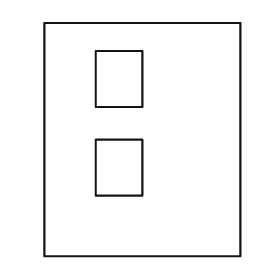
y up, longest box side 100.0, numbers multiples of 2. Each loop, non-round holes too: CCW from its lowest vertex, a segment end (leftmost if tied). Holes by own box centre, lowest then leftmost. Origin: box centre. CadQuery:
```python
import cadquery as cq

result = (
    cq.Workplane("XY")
    .moveTo(-42.0, -50.0)
    .lineTo(42.0, -50.0)
    .lineTo(42.0, 50.0)
    .lineTo(-42.0, 50.0)
    .close()
    .moveTo(-20.0, -24.0)
    .lineTo(0.0, -24.0)
    .lineTo(0.0, 0.0)
    .lineTo(-20.0, 0.0)
    .close()
    .moveTo(-20.0, 14.0)
    .lineTo(0.0, 14.0)
    .lineTo(0.0, 38.0)
    .lineTo(-20.0, 38.0)
    .close()
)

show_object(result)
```